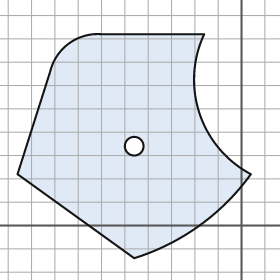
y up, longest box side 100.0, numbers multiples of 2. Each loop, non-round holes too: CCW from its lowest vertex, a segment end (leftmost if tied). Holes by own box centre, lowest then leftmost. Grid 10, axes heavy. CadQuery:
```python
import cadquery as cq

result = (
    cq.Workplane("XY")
    .moveTo(-46.0, -14.0)
    .threePointArc((-18.0, 0.0), (4.0, 22.0))
    .threePointArc((-18.0, 48.0), (-16.0, 82.0))
    .lineTo(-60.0, 82.0)
    .threePointArc((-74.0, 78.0), (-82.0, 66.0))
    .lineTo(-96.0, 22.0)
    .close()
    .moveTo(-46.0, 34.0)
    .circle(4.0)
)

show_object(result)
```